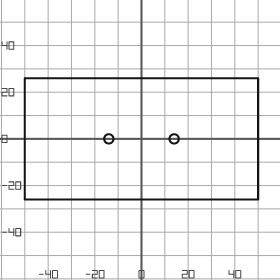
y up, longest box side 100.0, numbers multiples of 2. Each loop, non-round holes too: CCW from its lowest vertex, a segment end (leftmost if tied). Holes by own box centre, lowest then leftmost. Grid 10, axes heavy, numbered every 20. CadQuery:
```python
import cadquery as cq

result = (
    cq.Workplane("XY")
    .moveTo(-50.0, -26.0)
    .lineTo(50.0, -26.0)
    .lineTo(50.0, 26.0)
    .lineTo(-50.0, 26.0)
    .close()
    .moveTo(-14.0, 0.0)
    .circle(2.0)
    .moveTo(14.0, 0.0)
    .circle(2.0)
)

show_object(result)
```